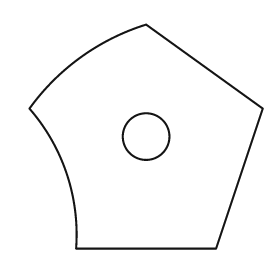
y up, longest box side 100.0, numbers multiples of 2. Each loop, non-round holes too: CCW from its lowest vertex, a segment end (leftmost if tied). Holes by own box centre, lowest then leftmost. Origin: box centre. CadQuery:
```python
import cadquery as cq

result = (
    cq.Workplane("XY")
    .moveTo(-30.0, -48.0)
    .lineTo(30.0, -48.0)
    .lineTo(50.0, 12.0)
    .lineTo(0.0, 48.0)
    .threePointArc((-28.0, 34.0), (-50.0, 12.0))
    .threePointArc((-34.0, -16.0), (-30.0, -48.0))
    .close()
    .moveTo(0.0, 0.0)
    .circle(10.0)
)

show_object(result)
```